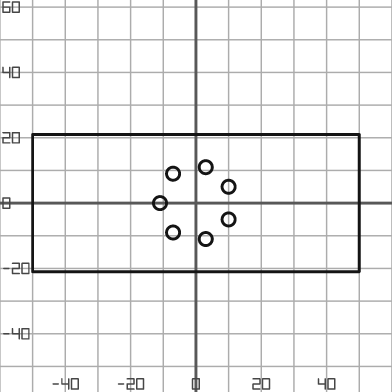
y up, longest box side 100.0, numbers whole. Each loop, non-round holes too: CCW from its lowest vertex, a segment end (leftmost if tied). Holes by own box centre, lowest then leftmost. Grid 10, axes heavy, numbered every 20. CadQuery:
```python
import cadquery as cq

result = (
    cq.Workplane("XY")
    .moveTo(-50.0, -21.0)
    .lineTo(50.0, -21.0)
    .lineTo(50.0, 21.0)
    .lineTo(-50.0, 21.0)
    .close()
    .moveTo(3.0, -11.0)
    .circle(2.0)
    .moveTo(-7.0, -9.0)
    .circle(2.0)
    .moveTo(10.0, -5.0)
    .circle(2.0)
    .moveTo(-11.0, 0.0)
    .circle(2.0)
    .moveTo(10.0, 5.0)
    .circle(2.0)
    .moveTo(-7.0, 9.0)
    .circle(2.0)
    .moveTo(3.0, 11.0)
    .circle(2.0)
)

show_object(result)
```